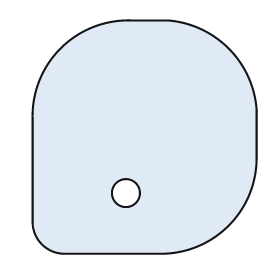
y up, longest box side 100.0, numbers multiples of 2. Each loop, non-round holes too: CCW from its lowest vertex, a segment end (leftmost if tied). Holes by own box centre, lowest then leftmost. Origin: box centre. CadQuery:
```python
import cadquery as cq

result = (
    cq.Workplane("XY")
    .moveTo(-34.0, -50.0)
    .lineTo(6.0, -50.0)
    .threePointArc((36.0, -38.0), (48.0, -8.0))
    .lineTo(48.0, 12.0)
    .threePointArc((36.0, 38.0), (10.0, 50.0))
    .lineTo(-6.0, 50.0)
    .threePointArc((-36.0, 38.0), (-48.0, 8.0))
    .lineTo(-48.0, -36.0)
    .threePointArc((-44.0, -46.0), (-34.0, -50.0))
    .close()
    .moveTo(-8.0, -24.0)
    .circle(6.0)
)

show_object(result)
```